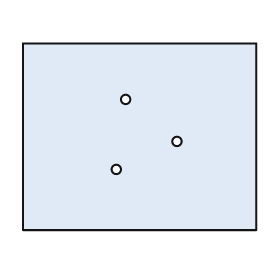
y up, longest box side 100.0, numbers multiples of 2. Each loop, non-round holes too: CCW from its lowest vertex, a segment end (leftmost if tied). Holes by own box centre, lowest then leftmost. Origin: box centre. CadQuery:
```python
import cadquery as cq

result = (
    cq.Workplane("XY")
    .moveTo(-50.0, -40.0)
    .lineTo(50.0, -40.0)
    .lineTo(50.0, 40.0)
    .lineTo(-50.0, 40.0)
    .close()
    .moveTo(-10.0, -14.0)
    .circle(2.0)
    .moveTo(16.0, -2.0)
    .circle(2.0)
    .moveTo(-6.0, 16.0)
    .circle(2.0)
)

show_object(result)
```